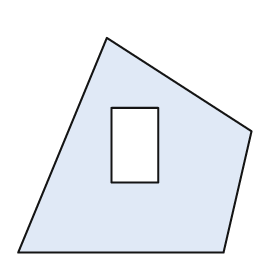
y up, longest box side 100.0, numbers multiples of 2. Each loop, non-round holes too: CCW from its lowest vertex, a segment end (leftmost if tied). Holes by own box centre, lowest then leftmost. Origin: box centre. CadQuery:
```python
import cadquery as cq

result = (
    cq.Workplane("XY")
    .moveTo(-50.0, -46.0)
    .lineTo(38.0, -46.0)
    .lineTo(50.0, 6.0)
    .lineTo(-12.0, 46.0)
    .close()
    .moveTo(-10.0, -16.0)
    .lineTo(10.0, -16.0)
    .lineTo(10.0, 16.0)
    .lineTo(-10.0, 16.0)
    .close()
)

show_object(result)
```